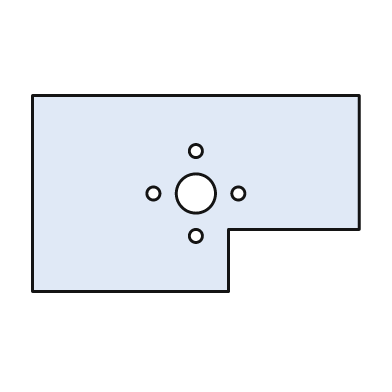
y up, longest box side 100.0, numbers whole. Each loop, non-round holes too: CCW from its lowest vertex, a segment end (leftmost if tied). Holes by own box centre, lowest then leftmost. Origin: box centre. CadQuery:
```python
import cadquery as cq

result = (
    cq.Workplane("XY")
    .moveTo(-50.0, -30.0)
    .lineTo(10.0, -30.0)
    .lineTo(10.0, -11.0)
    .lineTo(50.0, -11.0)
    .lineTo(50.0, 30.0)
    .lineTo(-50.0, 30.0)
    .close()
    .moveTo(0.0, -13.0)
    .circle(2.0)
    .moveTo(-13.0, 0.0)
    .circle(2.0)
    .moveTo(0.0, 0.0)
    .circle(6.0)
    .moveTo(13.0, 0.0)
    .circle(2.0)
    .moveTo(0.0, 13.0)
    .circle(2.0)
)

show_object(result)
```